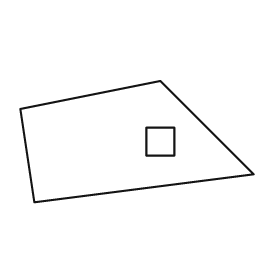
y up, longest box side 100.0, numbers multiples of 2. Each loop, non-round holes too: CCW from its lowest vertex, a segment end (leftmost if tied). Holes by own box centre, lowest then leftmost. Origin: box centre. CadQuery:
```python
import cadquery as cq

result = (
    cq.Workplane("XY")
    .moveTo(-44.0, -26.0)
    .lineTo(50.0, -14.0)
    .lineTo(10.0, 26.0)
    .lineTo(-50.0, 14.0)
    .close()
    .moveTo(4.0, -6.0)
    .lineTo(16.0, -6.0)
    .lineTo(16.0, 6.0)
    .lineTo(4.0, 6.0)
    .close()
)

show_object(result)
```